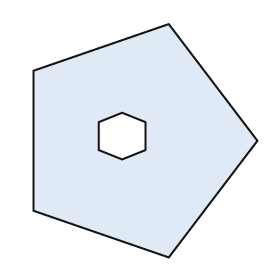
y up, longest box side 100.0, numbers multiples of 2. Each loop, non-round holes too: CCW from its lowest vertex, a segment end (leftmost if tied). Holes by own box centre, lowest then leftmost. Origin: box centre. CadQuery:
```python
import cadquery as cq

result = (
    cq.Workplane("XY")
    .moveTo(10.0, -50.0)
    .lineTo(48.0, 0.0)
    .lineTo(10.0, 50.0)
    .lineTo(-48.0, 30.0)
    .lineTo(-48.0, -30.0)
    .close()
    .moveTo(-10.0, -8.0)
    .lineTo(0.0, -4.0)
    .lineTo(0.0, 8.0)
    .lineTo(-10.0, 12.0)
    .lineTo(-20.0, 8.0)
    .lineTo(-20.0, -4.0)
    .close()
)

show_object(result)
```